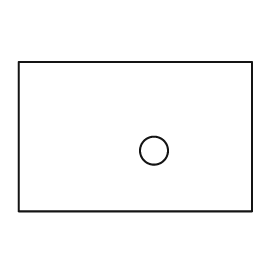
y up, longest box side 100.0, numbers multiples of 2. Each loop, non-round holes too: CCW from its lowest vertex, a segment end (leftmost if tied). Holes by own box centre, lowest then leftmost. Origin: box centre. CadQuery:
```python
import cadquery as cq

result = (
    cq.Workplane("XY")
    .moveTo(-50.0, -32.0)
    .lineTo(50.0, -32.0)
    .lineTo(50.0, 32.0)
    .lineTo(-50.0, 32.0)
    .close()
    .moveTo(8.0, -6.0)
    .circle(6.0)
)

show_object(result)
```